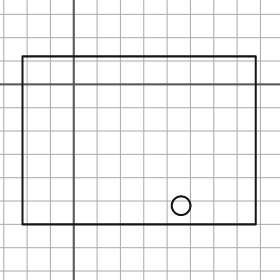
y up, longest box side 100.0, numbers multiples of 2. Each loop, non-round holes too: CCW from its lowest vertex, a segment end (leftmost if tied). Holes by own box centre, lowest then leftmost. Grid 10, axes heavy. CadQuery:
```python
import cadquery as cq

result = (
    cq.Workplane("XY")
    .moveTo(-22.0, -60.0)
    .lineTo(78.0, -60.0)
    .lineTo(78.0, 12.0)
    .lineTo(-22.0, 12.0)
    .close()
    .moveTo(46.0, -52.0)
    .circle(4.0)
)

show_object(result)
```